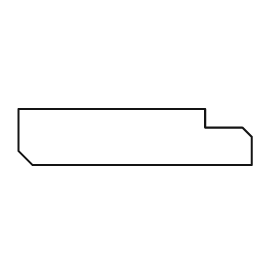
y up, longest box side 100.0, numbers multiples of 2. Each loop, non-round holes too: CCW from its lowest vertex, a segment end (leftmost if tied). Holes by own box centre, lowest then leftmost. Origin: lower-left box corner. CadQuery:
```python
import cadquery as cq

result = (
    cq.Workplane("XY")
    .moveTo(6.0, 0.0)
    .lineTo(100.0, 0.0)
    .lineTo(100.0, 12.0)
    .lineTo(96.0, 16.0)
    .lineTo(80.0, 16.0)
    .lineTo(80.0, 24.0)
    .lineTo(0.0, 24.0)
    .lineTo(0.0, 6.0)
    .close()
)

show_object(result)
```